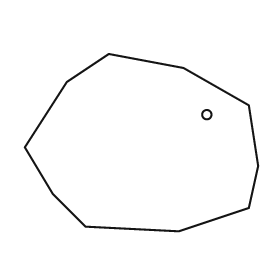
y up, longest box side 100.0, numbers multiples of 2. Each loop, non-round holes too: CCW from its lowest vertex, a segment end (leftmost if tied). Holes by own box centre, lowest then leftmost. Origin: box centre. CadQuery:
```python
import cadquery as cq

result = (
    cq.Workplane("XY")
    .moveTo(16.0, -38.0)
    .lineTo(46.0, -28.0)
    .lineTo(50.0, -10.0)
    .lineTo(46.0, 16.0)
    .lineTo(18.0, 32.0)
    .lineTo(-14.0, 38.0)
    .lineTo(-32.0, 26.0)
    .lineTo(-50.0, -2.0)
    .lineTo(-38.0, -22.0)
    .lineTo(-24.0, -36.0)
    .close()
    .moveTo(28.0, 12.0)
    .circle(2.0)
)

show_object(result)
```